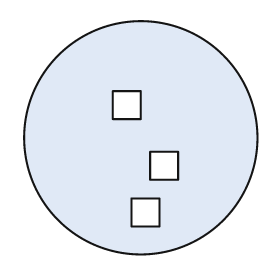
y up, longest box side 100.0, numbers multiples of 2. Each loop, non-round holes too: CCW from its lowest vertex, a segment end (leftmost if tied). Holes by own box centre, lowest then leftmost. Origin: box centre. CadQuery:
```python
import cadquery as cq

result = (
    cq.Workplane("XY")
    .moveTo(0.0, 0.0)
    .circle(50.0)
    .moveTo(-4.0, -38.0)
    .lineTo(8.0, -38.0)
    .lineTo(8.0, -26.0)
    .lineTo(-4.0, -26.0)
    .close()
    .moveTo(4.0, -18.0)
    .lineTo(16.0, -18.0)
    .lineTo(16.0, -6.0)
    .lineTo(4.0, -6.0)
    .close()
    .moveTo(-12.0, 8.0)
    .lineTo(0.0, 8.0)
    .lineTo(0.0, 20.0)
    .lineTo(-12.0, 20.0)
    .close()
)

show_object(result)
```